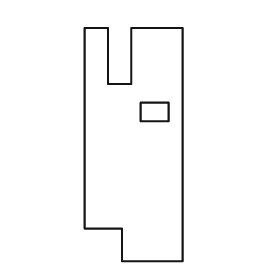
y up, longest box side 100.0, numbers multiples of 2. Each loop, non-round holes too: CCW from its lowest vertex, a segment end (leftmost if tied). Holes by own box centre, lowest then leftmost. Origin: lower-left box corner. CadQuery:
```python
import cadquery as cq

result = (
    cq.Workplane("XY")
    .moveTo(16.0, 0.0)
    .lineTo(42.0, 0.0)
    .lineTo(42.0, 100.0)
    .lineTo(20.0, 100.0)
    .lineTo(20.0, 76.0)
    .lineTo(10.0, 76.0)
    .lineTo(10.0, 100.0)
    .lineTo(0.0, 100.0)
    .lineTo(0.0, 14.0)
    .lineTo(16.0, 14.0)
    .close()
    .moveTo(24.0, 60.0)
    .lineTo(36.0, 60.0)
    .lineTo(36.0, 68.0)
    .lineTo(24.0, 68.0)
    .close()
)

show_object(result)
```